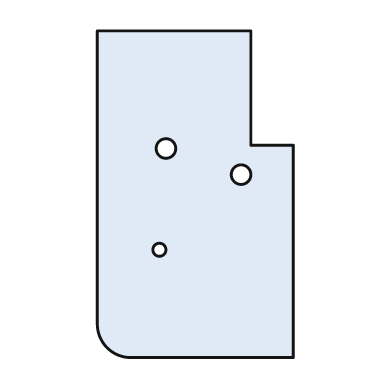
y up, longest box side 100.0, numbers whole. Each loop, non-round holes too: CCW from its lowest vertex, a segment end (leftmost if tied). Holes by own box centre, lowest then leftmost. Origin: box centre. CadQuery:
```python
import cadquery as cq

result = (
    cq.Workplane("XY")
    .moveTo(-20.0, -50.0)
    .lineTo(30.0, -50.0)
    .lineTo(30.0, 15.0)
    .lineTo(17.0, 15.0)
    .lineTo(17.0, 50.0)
    .lineTo(-30.0, 50.0)
    .lineTo(-30.0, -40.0)
    .threePointArc((-27.0, -47.0), (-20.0, -50.0))
    .close()
    .moveTo(-11.0, -17.0)
    .circle(2.0)
    .moveTo(14.0, 6.0)
    .circle(3.0)
    .moveTo(-9.0, 14.0)
    .circle(3.0)
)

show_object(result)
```